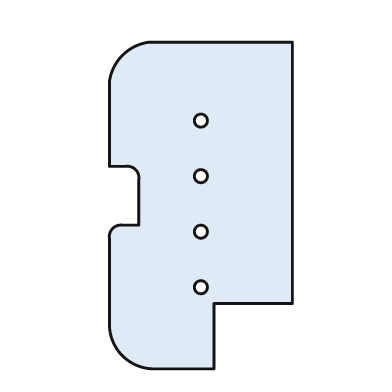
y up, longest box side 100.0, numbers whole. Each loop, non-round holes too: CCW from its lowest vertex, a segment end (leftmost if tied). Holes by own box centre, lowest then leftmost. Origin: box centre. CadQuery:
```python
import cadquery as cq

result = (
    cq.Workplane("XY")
    .moveTo(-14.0, -50.0)
    .lineTo(4.0, -50.0)
    .lineTo(4.0, -30.0)
    .lineTo(28.0, -30.0)
    .lineTo(28.0, 50.0)
    .lineTo(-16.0, 50.0)
    .threePointArc((-24.0, 46.0), (-28.0, 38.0))
    .lineTo(-28.0, 12.0)
    .lineTo(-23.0, 12.0)
    .threePointArc((-20.0, 11.0), (-19.0, 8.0))
    .lineTo(-19.0, -6.0)
    .lineTo(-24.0, -6.0)
    .threePointArc((-27.0, -7.0), (-28.0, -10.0))
    .lineTo(-28.0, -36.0)
    .threePointArc((-24.0, -46.0), (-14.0, -50.0))
    .close()
    .moveTo(0.0, -25.0)
    .circle(2.0)
    .moveTo(0.0, -8.0)
    .circle(2.0)
    .moveTo(0.0, 9.0)
    .circle(2.0)
    .moveTo(0.0, 26.0)
    .circle(2.0)
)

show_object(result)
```